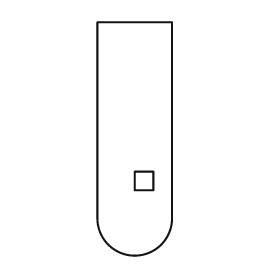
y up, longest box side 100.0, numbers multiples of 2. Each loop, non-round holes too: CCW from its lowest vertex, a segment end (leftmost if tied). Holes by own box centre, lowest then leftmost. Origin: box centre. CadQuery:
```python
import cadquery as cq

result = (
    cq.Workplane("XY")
    .moveTo(-16.0, -34.0)
    .threePointArc((0.0, -50.0), (16.0, -34.0))
    .lineTo(16.0, 50.0)
    .lineTo(-16.0, 50.0)
    .close()
    .moveTo(0.0, -22.0)
    .lineTo(8.0, -22.0)
    .lineTo(8.0, -14.0)
    .lineTo(0.0, -14.0)
    .close()
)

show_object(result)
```